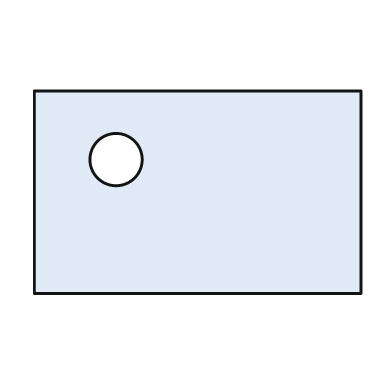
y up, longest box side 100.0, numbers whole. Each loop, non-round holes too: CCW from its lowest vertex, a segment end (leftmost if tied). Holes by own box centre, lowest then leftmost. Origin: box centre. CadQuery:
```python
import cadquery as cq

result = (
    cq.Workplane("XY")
    .moveTo(-50.0, -31.0)
    .lineTo(50.0, -31.0)
    .lineTo(50.0, 31.0)
    .lineTo(-50.0, 31.0)
    .close()
    .moveTo(-25.0, 10.0)
    .circle(8.0)
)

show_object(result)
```